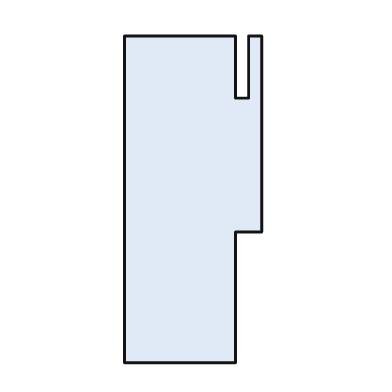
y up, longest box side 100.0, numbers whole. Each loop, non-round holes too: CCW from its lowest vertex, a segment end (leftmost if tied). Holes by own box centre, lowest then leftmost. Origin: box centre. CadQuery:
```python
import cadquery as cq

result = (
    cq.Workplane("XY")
    .moveTo(-21.0, -50.0)
    .lineTo(13.0, -50.0)
    .lineTo(13.0, -10.0)
    .lineTo(21.0, -10.0)
    .lineTo(21.0, 50.0)
    .lineTo(17.0, 50.0)
    .lineTo(17.0, 31.0)
    .lineTo(13.0, 31.0)
    .lineTo(13.0, 50.0)
    .lineTo(-21.0, 50.0)
    .close()
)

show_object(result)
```